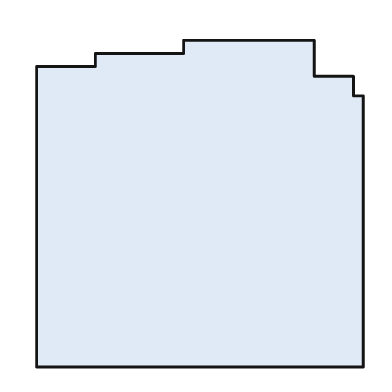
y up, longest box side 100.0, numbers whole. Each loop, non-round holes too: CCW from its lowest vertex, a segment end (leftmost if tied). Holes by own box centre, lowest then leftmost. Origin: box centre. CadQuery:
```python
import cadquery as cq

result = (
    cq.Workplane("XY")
    .moveTo(-50.0, -50.0)
    .lineTo(50.0, -50.0)
    .lineTo(50.0, 33.0)
    .lineTo(47.0, 33.0)
    .lineTo(47.0, 39.0)
    .lineTo(35.0, 39.0)
    .lineTo(35.0, 50.0)
    .lineTo(-5.0, 50.0)
    .lineTo(-5.0, 46.0)
    .lineTo(-32.0, 46.0)
    .lineTo(-32.0, 42.0)
    .lineTo(-50.0, 42.0)
    .close()
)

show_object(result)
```